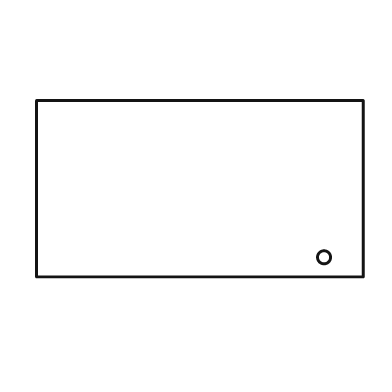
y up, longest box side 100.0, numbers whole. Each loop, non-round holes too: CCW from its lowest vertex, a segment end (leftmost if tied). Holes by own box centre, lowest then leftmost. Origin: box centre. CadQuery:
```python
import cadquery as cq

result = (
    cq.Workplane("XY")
    .moveTo(-50.0, -27.0)
    .lineTo(50.0, -27.0)
    .lineTo(50.0, 27.0)
    .lineTo(-50.0, 27.0)
    .close()
    .moveTo(38.0, -21.0)
    .circle(2.0)
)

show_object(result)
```